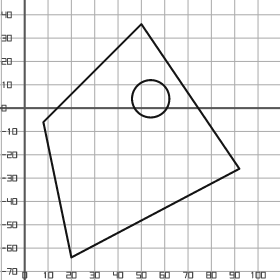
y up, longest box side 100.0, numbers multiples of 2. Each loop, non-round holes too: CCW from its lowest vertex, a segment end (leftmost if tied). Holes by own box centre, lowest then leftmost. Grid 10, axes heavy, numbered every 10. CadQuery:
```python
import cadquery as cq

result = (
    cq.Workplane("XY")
    .moveTo(20.0, -64.0)
    .lineTo(92.0, -26.0)
    .lineTo(50.0, 36.0)
    .lineTo(8.0, -6.0)
    .close()
    .moveTo(54.0, 4.0)
    .circle(8.0)
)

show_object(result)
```